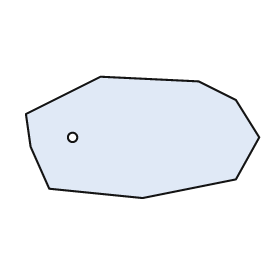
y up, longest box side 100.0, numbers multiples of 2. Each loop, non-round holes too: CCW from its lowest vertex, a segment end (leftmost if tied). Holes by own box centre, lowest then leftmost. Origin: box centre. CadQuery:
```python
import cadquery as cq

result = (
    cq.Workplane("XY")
    .moveTo(0.0, -26.0)
    .lineTo(40.0, -18.0)
    .lineTo(50.0, 0.0)
    .lineTo(40.0, 16.0)
    .lineTo(24.0, 24.0)
    .lineTo(-18.0, 26.0)
    .lineTo(-50.0, 10.0)
    .lineTo(-48.0, -4.0)
    .lineTo(-40.0, -22.0)
    .close()
    .moveTo(-30.0, 0.0)
    .circle(2.0)
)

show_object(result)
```